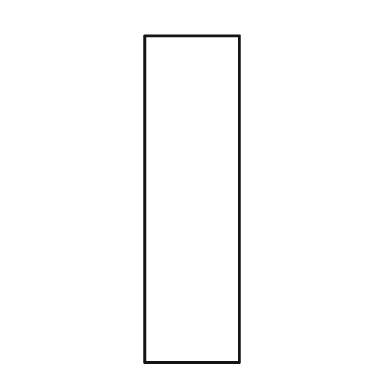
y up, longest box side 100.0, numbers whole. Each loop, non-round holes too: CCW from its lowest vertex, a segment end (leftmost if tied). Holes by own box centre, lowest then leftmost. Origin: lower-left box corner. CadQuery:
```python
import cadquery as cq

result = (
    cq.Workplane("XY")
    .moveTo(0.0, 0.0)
    .lineTo(29.0, 0.0)
    .lineTo(29.0, 100.0)
    .lineTo(0.0, 100.0)
    .close()
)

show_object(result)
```